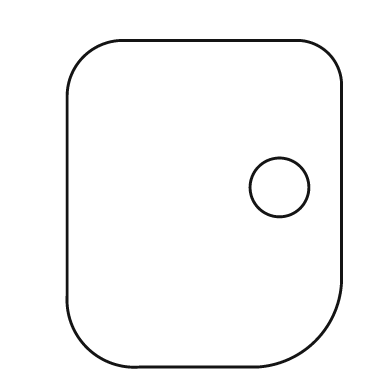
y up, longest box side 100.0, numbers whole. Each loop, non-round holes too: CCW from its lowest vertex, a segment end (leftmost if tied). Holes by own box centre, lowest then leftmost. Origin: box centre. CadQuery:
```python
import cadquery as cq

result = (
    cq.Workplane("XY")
    .moveTo(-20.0, -50.0)
    .lineTo(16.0, -50.0)
    .threePointArc((34.0, -42.0), (42.0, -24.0))
    .lineTo(42.0, 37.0)
    .threePointArc((38.0, 46.0), (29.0, 50.0))
    .lineTo(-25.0, 50.0)
    .threePointArc((-37.0, 45.0), (-42.0, 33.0))
    .lineTo(-42.0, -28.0)
    .threePointArc((-36.0, -44.0), (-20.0, -50.0))
    .close()
    .moveTo(23.0, 5.0)
    .circle(9.0)
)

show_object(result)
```